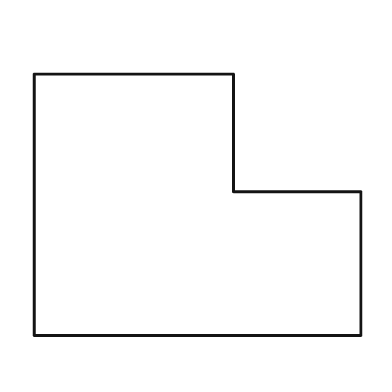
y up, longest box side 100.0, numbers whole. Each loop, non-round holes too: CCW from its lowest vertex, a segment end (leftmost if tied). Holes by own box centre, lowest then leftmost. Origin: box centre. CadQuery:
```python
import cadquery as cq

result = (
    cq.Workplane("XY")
    .moveTo(-50.0, -40.0)
    .lineTo(50.0, -40.0)
    .lineTo(50.0, 4.0)
    .lineTo(11.0, 4.0)
    .lineTo(11.0, 40.0)
    .lineTo(-50.0, 40.0)
    .close()
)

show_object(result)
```